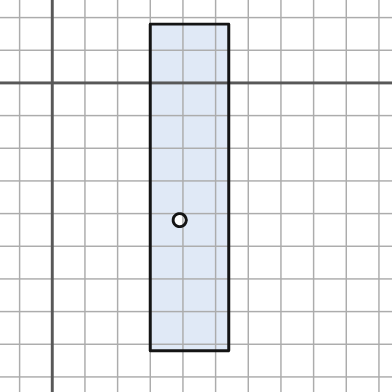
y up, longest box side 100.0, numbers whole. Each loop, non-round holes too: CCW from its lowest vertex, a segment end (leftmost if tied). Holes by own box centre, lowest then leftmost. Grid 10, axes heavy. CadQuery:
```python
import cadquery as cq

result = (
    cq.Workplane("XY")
    .moveTo(30.0, -82.0)
    .lineTo(54.0, -82.0)
    .lineTo(54.0, 18.0)
    .lineTo(30.0, 18.0)
    .close()
    .moveTo(39.0, -42.0)
    .circle(2.0)
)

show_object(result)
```